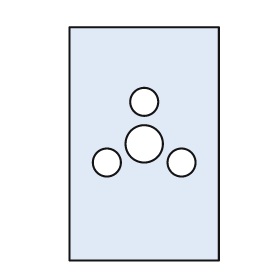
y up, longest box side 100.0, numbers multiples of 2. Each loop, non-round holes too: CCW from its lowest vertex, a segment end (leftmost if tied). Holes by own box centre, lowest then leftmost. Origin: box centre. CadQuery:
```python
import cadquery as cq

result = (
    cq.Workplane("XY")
    .moveTo(-32.0, -50.0)
    .lineTo(32.0, -50.0)
    .lineTo(32.0, 50.0)
    .lineTo(-32.0, 50.0)
    .close()
    .moveTo(-16.0, -8.0)
    .circle(6.0)
    .moveTo(16.0, -8.0)
    .circle(6.0)
    .moveTo(0.0, 0.0)
    .circle(8.0)
    .moveTo(0.0, 18.0)
    .circle(6.0)
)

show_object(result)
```